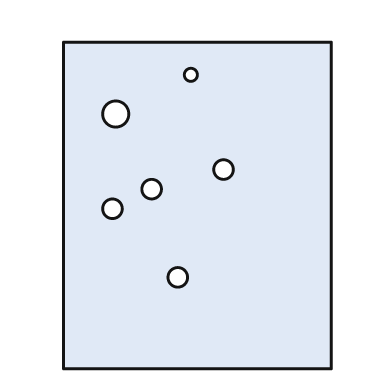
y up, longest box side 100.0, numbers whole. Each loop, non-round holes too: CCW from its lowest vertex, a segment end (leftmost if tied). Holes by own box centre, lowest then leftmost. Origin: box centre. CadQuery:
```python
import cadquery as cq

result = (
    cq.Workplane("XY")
    .moveTo(-41.0, -50.0)
    .lineTo(41.0, -50.0)
    .lineTo(41.0, 50.0)
    .lineTo(-41.0, 50.0)
    .close()
    .moveTo(-6.0, -22.0)
    .circle(3.0)
    .moveTo(-26.0, -1.0)
    .circle(3.0)
    .moveTo(-14.0, 5.0)
    .circle(3.0)
    .moveTo(8.0, 11.0)
    .circle(3.0)
    .moveTo(-25.0, 28.0)
    .circle(4.0)
    .moveTo(-2.0, 40.0)
    .circle(2.0)
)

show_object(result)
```